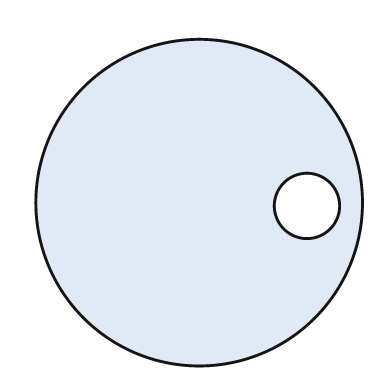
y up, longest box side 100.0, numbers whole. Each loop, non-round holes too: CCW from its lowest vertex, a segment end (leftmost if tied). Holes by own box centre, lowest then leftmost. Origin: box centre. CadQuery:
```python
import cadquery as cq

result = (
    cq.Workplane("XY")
    .moveTo(0.0, 0.0)
    .circle(50.0)
    .moveTo(33.0, -1.0)
    .circle(10.0)
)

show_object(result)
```